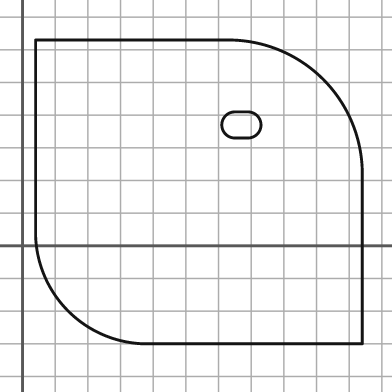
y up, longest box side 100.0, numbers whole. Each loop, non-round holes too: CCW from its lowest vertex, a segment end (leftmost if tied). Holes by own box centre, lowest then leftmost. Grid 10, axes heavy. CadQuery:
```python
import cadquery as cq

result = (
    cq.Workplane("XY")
    .moveTo(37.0, -30.0)
    .lineTo(104.0, -30.0)
    .lineTo(104.0, 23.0)
    .threePointArc((92.0, 51.0), (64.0, 63.0))
    .lineTo(4.0, 63.0)
    .lineTo(4.0, 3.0)
    .threePointArc((14.0, -20.0), (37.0, -30.0))
    .close()
    .moveTo(65.0, 33.0)
    .lineTo(69.0, 33.0)
    .threePointArc((73.0, 37.0), (69.0, 41.0))
    .lineTo(65.0, 41.0)
    .threePointArc((61.0, 37.0), (65.0, 33.0))
    .close()
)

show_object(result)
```